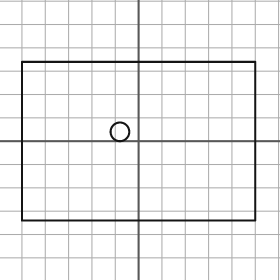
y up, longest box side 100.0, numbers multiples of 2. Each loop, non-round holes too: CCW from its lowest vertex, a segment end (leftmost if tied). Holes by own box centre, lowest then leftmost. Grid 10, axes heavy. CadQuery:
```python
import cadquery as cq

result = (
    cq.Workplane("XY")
    .moveTo(-50.0, -34.0)
    .lineTo(50.0, -34.0)
    .lineTo(50.0, 34.0)
    .lineTo(-50.0, 34.0)
    .close()
    .moveTo(-8.0, 4.0)
    .circle(4.0)
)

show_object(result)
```